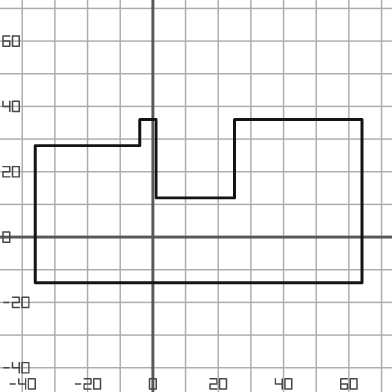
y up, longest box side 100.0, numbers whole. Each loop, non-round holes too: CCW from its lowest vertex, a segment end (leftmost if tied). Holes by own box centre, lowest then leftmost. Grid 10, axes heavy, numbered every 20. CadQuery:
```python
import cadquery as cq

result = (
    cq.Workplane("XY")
    .moveTo(-36.0, -14.0)
    .lineTo(64.0, -14.0)
    .lineTo(64.0, 36.0)
    .lineTo(25.0, 36.0)
    .lineTo(25.0, 12.0)
    .lineTo(1.0, 12.0)
    .lineTo(1.0, 36.0)
    .lineTo(-4.0, 36.0)
    .lineTo(-4.0, 28.0)
    .lineTo(-36.0, 28.0)
    .close()
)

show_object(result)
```